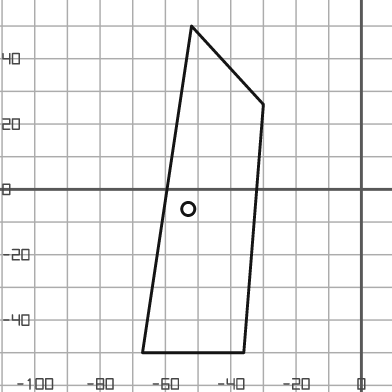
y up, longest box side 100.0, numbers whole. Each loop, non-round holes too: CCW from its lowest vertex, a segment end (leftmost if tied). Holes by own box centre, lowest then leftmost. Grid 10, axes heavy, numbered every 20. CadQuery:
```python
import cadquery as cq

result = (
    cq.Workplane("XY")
    .moveTo(-67.0, -50.0)
    .lineTo(-36.0, -50.0)
    .lineTo(-30.0, 26.0)
    .lineTo(-52.0, 50.0)
    .close()
    .moveTo(-53.0, -6.0)
    .circle(2.0)
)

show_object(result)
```